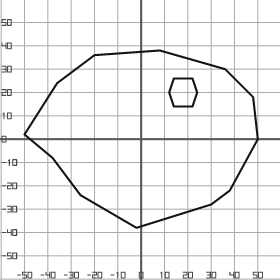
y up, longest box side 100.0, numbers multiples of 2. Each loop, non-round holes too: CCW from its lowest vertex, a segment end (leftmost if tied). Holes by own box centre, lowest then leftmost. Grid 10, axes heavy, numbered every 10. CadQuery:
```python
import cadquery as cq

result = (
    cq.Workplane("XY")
    .moveTo(-2.0, -38.0)
    .lineTo(30.0, -28.0)
    .lineTo(38.0, -22.0)
    .lineTo(50.0, 0.0)
    .lineTo(48.0, 18.0)
    .lineTo(36.0, 30.0)
    .lineTo(8.0, 38.0)
    .lineTo(-20.0, 36.0)
    .lineTo(-36.0, 24.0)
    .lineTo(-50.0, 2.0)
    .lineTo(-38.0, -8.0)
    .lineTo(-26.0, -24.0)
    .close()
    .moveTo(14.0, 14.0)
    .lineTo(22.0, 14.0)
    .lineTo(24.0, 20.0)
    .lineTo(22.0, 26.0)
    .lineTo(14.0, 26.0)
    .lineTo(12.0, 20.0)
    .close()
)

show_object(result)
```